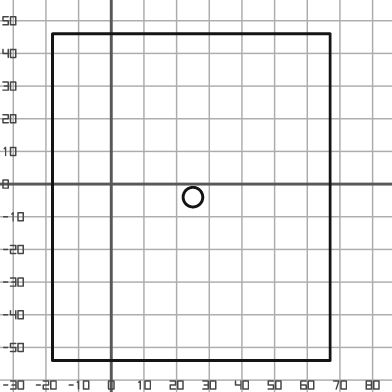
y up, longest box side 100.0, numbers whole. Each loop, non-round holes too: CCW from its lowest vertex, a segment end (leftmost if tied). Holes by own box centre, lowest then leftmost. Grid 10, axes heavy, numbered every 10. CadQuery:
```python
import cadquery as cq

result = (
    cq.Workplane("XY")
    .moveTo(-18.0, -54.0)
    .lineTo(67.0, -54.0)
    .lineTo(67.0, 46.0)
    .lineTo(-18.0, 46.0)
    .close()
    .moveTo(25.0, -4.0)
    .circle(3.0)
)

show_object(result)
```